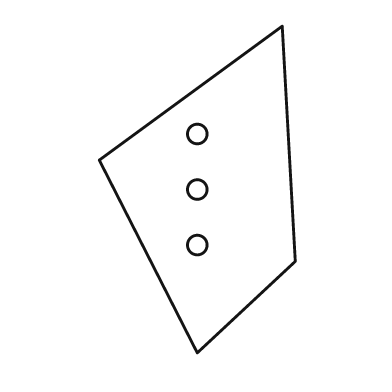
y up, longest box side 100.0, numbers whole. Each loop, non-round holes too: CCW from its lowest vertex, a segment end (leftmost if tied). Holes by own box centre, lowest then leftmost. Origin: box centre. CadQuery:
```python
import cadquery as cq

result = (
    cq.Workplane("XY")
    .moveTo(0.0, -50.0)
    .lineTo(30.0, -22.0)
    .lineTo(26.0, 50.0)
    .lineTo(-30.0, 9.0)
    .close()
    .moveTo(0.0, -17.0)
    .circle(3.0)
    .moveTo(0.0, 0.0)
    .circle(3.0)
    .moveTo(0.0, 17.0)
    .circle(3.0)
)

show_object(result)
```